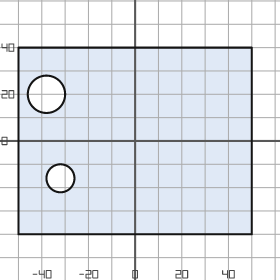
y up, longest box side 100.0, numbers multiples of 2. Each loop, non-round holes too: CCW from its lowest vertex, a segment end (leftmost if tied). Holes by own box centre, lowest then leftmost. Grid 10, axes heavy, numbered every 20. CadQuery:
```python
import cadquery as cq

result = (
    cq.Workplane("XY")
    .moveTo(-50.0, -40.0)
    .lineTo(50.0, -40.0)
    .lineTo(50.0, 40.0)
    .lineTo(-50.0, 40.0)
    .close()
    .moveTo(-32.0, -16.0)
    .circle(6.0)
    .moveTo(-38.0, 20.0)
    .circle(8.0)
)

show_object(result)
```